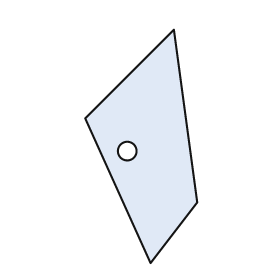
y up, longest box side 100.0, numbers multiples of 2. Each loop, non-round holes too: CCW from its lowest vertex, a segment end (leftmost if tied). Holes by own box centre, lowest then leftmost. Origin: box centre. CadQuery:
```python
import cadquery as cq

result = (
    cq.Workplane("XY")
    .moveTo(4.0, -50.0)
    .lineTo(24.0, -24.0)
    .lineTo(14.0, 50.0)
    .lineTo(-24.0, 12.0)
    .close()
    .moveTo(-6.0, -2.0)
    .circle(4.0)
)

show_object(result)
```